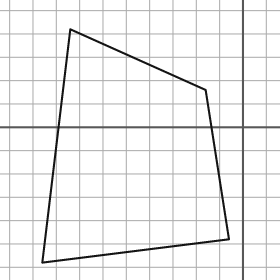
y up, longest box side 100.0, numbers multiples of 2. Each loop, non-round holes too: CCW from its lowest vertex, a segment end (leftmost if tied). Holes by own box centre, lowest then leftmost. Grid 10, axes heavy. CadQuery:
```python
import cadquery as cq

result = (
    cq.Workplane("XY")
    .moveTo(-86.0, -58.0)
    .lineTo(-6.0, -48.0)
    .lineTo(-16.0, 16.0)
    .lineTo(-74.0, 42.0)
    .close()
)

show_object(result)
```